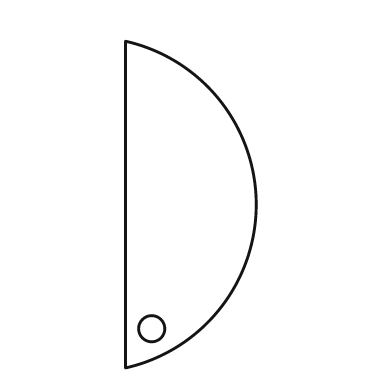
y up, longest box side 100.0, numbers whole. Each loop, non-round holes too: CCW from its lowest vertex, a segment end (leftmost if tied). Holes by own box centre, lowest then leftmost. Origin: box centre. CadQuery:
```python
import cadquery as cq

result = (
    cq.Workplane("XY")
    .moveTo(-20.0, -50.0)
    .threePointArc((20.0, 0.0), (-20.0, 50.0))
    .close()
    .moveTo(-12.0, -38.0)
    .circle(4.0)
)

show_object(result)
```